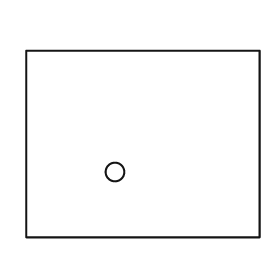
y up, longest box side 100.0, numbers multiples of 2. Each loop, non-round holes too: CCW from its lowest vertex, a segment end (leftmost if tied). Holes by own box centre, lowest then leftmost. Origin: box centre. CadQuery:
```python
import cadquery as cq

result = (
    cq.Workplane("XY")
    .moveTo(-50.0, -40.0)
    .lineTo(50.0, -40.0)
    .lineTo(50.0, 40.0)
    .lineTo(-50.0, 40.0)
    .close()
    .moveTo(-12.0, -12.0)
    .circle(4.0)
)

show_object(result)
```